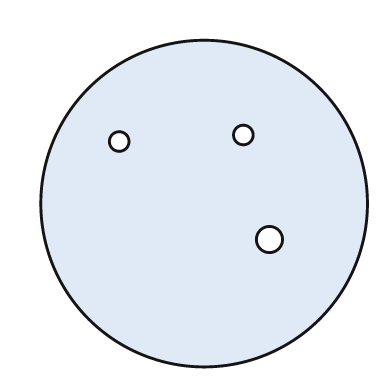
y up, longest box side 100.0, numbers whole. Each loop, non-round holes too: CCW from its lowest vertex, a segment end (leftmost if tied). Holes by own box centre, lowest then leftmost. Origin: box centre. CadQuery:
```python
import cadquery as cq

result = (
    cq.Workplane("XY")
    .moveTo(0.0, 0.0)
    .circle(50.0)
    .moveTo(20.0, -11.0)
    .circle(4.0)
    .moveTo(-26.0, 19.0)
    .circle(3.0)
    .moveTo(12.0, 21.0)
    .circle(3.0)
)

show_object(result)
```